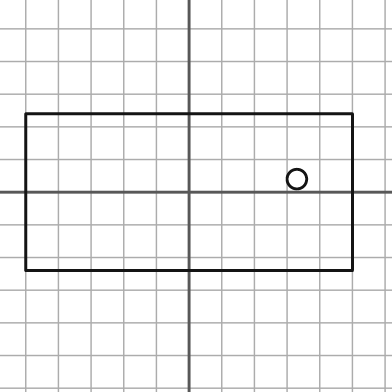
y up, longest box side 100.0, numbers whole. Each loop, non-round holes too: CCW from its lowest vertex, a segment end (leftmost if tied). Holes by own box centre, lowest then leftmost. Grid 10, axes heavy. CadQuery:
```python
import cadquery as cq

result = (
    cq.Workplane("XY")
    .moveTo(-50.0, -24.0)
    .lineTo(50.0, -24.0)
    .lineTo(50.0, 24.0)
    .lineTo(-50.0, 24.0)
    .close()
    .moveTo(33.0, 4.0)
    .circle(3.0)
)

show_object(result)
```